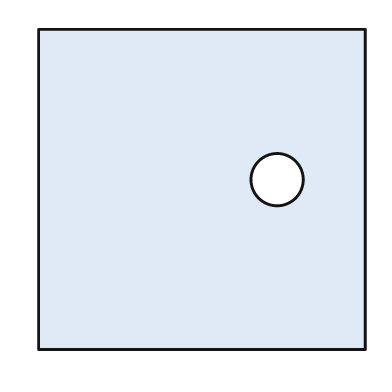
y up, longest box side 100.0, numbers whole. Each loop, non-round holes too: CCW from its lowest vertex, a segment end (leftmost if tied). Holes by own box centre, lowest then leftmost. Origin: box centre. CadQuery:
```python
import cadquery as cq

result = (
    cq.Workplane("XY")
    .moveTo(-50.0, -49.0)
    .lineTo(50.0, -49.0)
    .lineTo(50.0, 49.0)
    .lineTo(-50.0, 49.0)
    .close()
    .moveTo(23.0, 3.0)
    .circle(8.0)
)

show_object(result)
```